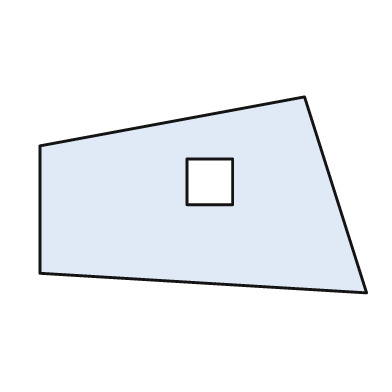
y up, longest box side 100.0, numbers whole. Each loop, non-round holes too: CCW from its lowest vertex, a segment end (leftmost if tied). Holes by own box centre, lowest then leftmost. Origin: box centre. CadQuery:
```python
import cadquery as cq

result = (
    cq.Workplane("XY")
    .moveTo(50.0, -30.0)
    .lineTo(31.0, 30.0)
    .lineTo(-50.0, 15.0)
    .lineTo(-50.0, -24.0)
    .close()
    .moveTo(-5.0, -3.0)
    .lineTo(9.0, -3.0)
    .lineTo(9.0, 11.0)
    .lineTo(-5.0, 11.0)
    .close()
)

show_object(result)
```